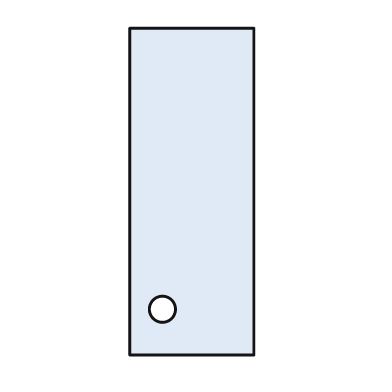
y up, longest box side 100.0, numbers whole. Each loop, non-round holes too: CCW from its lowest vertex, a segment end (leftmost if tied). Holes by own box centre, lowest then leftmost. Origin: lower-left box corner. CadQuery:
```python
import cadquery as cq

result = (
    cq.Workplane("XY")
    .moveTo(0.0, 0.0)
    .lineTo(38.0, 0.0)
    .lineTo(38.0, 100.0)
    .lineTo(0.0, 100.0)
    .close()
    .moveTo(10.0, 14.0)
    .circle(4.0)
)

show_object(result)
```